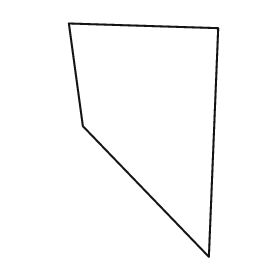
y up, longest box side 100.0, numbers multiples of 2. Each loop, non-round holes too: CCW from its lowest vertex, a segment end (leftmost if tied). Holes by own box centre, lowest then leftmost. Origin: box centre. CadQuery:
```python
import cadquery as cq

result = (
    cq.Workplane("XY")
    .moveTo(28.0, -50.0)
    .lineTo(32.0, 48.0)
    .lineTo(-32.0, 50.0)
    .lineTo(-26.0, 6.0)
    .close()
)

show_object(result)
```